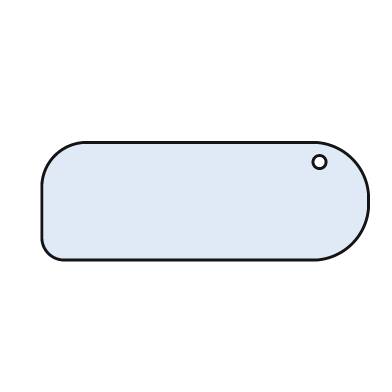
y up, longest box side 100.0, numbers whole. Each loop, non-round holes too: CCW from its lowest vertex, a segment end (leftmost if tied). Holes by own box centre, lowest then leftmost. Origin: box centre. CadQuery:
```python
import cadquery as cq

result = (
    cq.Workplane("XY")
    .moveTo(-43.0, -18.0)
    .lineTo(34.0, -18.0)
    .threePointArc((45.0, -13.0), (50.0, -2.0))
    .lineTo(50.0, 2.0)
    .threePointArc((45.0, 13.0), (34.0, 18.0))
    .lineTo(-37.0, 18.0)
    .threePointArc((-46.0, 14.0), (-50.0, 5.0))
    .lineTo(-50.0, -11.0)
    .threePointArc((-48.0, -16.0), (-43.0, -18.0))
    .close()
    .moveTo(35.0, 12.0)
    .circle(2.0)
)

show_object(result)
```